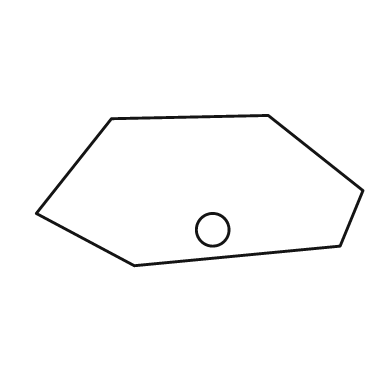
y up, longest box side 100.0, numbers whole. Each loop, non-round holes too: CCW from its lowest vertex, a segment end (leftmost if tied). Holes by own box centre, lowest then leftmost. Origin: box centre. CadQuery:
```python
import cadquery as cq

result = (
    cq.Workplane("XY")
    .moveTo(-20.0, -23.0)
    .lineTo(43.0, -17.0)
    .lineTo(50.0, 0.0)
    .lineTo(21.0, 23.0)
    .lineTo(-27.0, 22.0)
    .lineTo(-50.0, -7.0)
    .close()
    .moveTo(4.0, -12.0)
    .circle(5.0)
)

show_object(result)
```